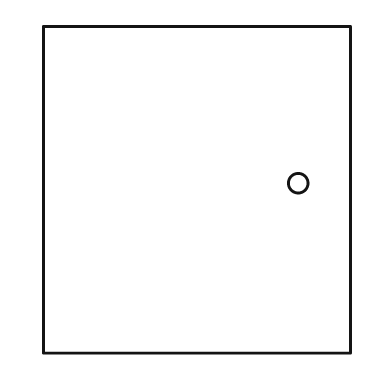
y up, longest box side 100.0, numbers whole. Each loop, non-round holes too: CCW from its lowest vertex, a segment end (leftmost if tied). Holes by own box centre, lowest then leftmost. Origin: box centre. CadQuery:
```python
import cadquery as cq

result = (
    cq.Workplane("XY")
    .moveTo(-47.0, -50.0)
    .lineTo(47.0, -50.0)
    .lineTo(47.0, 50.0)
    .lineTo(-47.0, 50.0)
    .close()
    .moveTo(31.0, 2.0)
    .circle(3.0)
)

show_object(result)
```